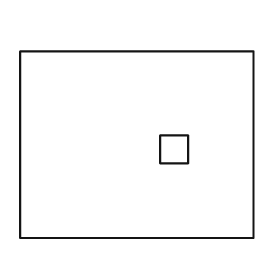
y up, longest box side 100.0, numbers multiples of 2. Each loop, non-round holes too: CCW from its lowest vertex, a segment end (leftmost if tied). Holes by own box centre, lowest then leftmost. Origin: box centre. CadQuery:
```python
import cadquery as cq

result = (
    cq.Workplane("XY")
    .moveTo(-50.0, -40.0)
    .lineTo(50.0, -40.0)
    .lineTo(50.0, 40.0)
    .lineTo(-50.0, 40.0)
    .close()
    .moveTo(10.0, -8.0)
    .lineTo(22.0, -8.0)
    .lineTo(22.0, 4.0)
    .lineTo(10.0, 4.0)
    .close()
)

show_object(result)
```